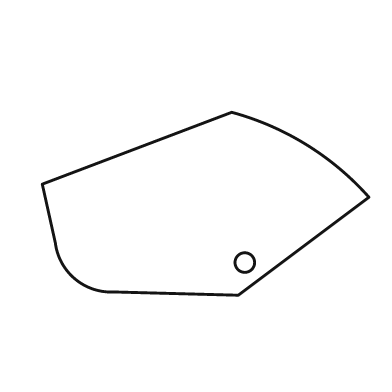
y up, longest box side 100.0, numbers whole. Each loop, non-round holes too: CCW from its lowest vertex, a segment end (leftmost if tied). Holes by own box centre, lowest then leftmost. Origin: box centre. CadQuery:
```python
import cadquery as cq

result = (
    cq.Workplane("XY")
    .moveTo(10.0, -28.0)
    .lineTo(50.0, 2.0)
    .threePointArc((31.0, 18.0), (8.0, 28.0))
    .lineTo(-50.0, 6.0)
    .lineTo(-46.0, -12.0)
    .threePointArc((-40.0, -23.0), (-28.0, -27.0))
    .close()
    .moveTo(12.0, -18.0)
    .circle(3.0)
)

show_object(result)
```